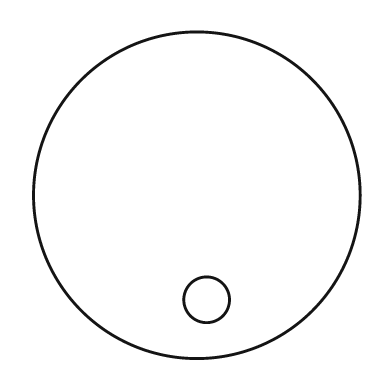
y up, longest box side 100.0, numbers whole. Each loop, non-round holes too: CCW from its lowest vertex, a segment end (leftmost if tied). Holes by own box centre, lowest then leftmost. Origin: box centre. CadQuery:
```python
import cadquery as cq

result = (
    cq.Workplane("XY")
    .moveTo(0.0, 0.0)
    .circle(50.0)
    .moveTo(3.0, -32.0)
    .circle(7.0)
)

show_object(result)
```